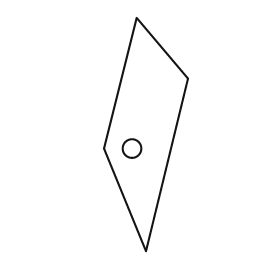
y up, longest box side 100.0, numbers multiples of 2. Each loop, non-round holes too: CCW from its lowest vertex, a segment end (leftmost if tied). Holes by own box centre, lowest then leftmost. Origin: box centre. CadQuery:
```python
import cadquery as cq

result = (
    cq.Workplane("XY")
    .moveTo(0.0, -50.0)
    .lineTo(18.0, 24.0)
    .lineTo(-4.0, 50.0)
    .lineTo(-18.0, -6.0)
    .close()
    .moveTo(-6.0, -6.0)
    .circle(4.0)
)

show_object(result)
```